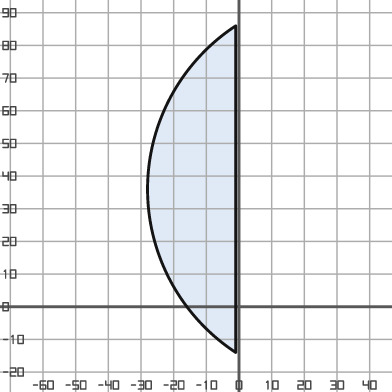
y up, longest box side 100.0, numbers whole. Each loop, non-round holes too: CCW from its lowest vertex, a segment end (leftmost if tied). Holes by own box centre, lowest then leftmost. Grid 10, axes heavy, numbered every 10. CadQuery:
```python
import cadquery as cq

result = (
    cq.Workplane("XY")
    .moveTo(-1.0, -14.0)
    .lineTo(-1.0, 86.0)
    .threePointArc((-28.0, 36.0), (-1.0, -14.0))
    .close()
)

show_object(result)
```